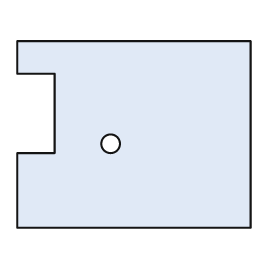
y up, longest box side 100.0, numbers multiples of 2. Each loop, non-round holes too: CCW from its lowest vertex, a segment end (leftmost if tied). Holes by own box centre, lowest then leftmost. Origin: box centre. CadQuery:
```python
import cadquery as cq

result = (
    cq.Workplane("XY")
    .moveTo(-50.0, -40.0)
    .lineTo(50.0, -40.0)
    .lineTo(50.0, 40.0)
    .lineTo(-50.0, 40.0)
    .lineTo(-50.0, 26.0)
    .lineTo(-34.0, 26.0)
    .lineTo(-34.0, -8.0)
    .lineTo(-50.0, -8.0)
    .close()
    .moveTo(-10.0, -4.0)
    .circle(4.0)
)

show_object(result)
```